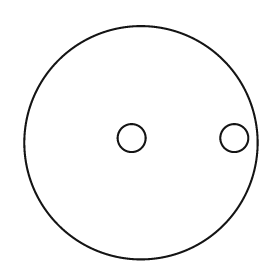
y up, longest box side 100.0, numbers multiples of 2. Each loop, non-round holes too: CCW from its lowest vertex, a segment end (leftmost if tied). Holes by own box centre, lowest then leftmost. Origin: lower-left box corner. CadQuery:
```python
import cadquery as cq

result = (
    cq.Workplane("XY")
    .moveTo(50.0, 50.0)
    .circle(50.0)
    .moveTo(46.0, 52.0)
    .circle(6.0)
    .moveTo(90.0, 52.0)
    .circle(6.0)
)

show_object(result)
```